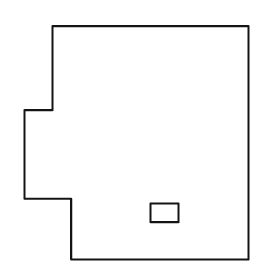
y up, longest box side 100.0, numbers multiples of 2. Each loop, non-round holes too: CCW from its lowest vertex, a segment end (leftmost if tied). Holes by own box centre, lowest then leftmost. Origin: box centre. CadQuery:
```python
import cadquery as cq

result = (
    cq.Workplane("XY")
    .moveTo(-28.0, -50.0)
    .lineTo(48.0, -50.0)
    .lineTo(48.0, 50.0)
    .lineTo(-36.0, 50.0)
    .lineTo(-36.0, 14.0)
    .lineTo(-48.0, 14.0)
    .lineTo(-48.0, -24.0)
    .lineTo(-28.0, -24.0)
    .close()
    .moveTo(6.0, -34.0)
    .lineTo(18.0, -34.0)
    .lineTo(18.0, -26.0)
    .lineTo(6.0, -26.0)
    .close()
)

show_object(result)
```